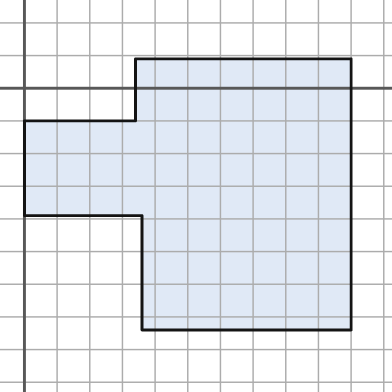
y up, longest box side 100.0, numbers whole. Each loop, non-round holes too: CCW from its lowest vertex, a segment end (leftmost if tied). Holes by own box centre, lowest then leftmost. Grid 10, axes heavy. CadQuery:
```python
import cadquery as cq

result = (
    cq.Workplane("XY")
    .moveTo(36.0, -74.0)
    .lineTo(100.0, -74.0)
    .lineTo(100.0, 9.0)
    .lineTo(34.0, 9.0)
    .lineTo(34.0, -10.0)
    .lineTo(0.0, -10.0)
    .lineTo(0.0, -39.0)
    .lineTo(36.0, -39.0)
    .close()
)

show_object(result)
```